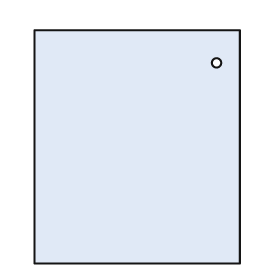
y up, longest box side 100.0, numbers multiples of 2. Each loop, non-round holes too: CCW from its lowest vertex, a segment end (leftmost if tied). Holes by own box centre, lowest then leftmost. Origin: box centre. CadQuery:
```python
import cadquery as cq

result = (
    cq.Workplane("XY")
    .moveTo(-44.0, -50.0)
    .lineTo(44.0, -50.0)
    .lineTo(44.0, 50.0)
    .lineTo(-44.0, 50.0)
    .close()
    .moveTo(34.0, 36.0)
    .circle(2.0)
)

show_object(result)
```